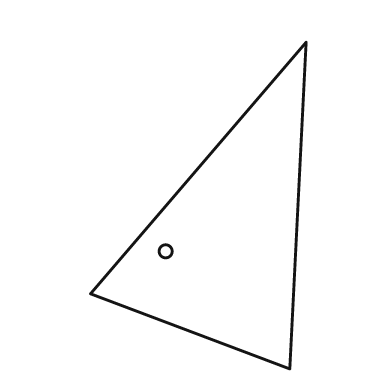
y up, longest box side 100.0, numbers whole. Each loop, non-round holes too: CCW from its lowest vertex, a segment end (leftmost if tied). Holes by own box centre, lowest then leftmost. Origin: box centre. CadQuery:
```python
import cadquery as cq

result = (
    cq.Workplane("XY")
    .moveTo(28.0, -50.0)
    .lineTo(33.0, 50.0)
    .lineTo(-33.0, -27.0)
    .close()
    .moveTo(-10.0, -14.0)
    .circle(2.0)
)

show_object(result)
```